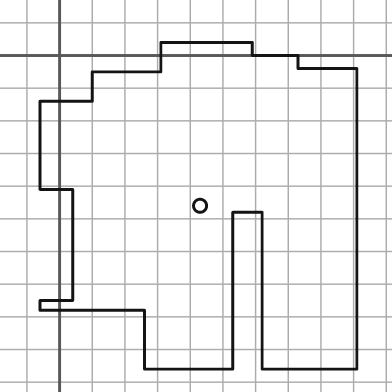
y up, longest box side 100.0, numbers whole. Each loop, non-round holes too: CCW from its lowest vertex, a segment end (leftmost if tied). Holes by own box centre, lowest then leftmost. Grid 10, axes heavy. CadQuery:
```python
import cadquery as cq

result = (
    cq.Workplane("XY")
    .moveTo(26.0, -96.0)
    .lineTo(53.0, -96.0)
    .lineTo(53.0, -48.0)
    .lineTo(62.0, -48.0)
    .lineTo(62.0, -96.0)
    .lineTo(91.0, -96.0)
    .lineTo(91.0, -4.0)
    .lineTo(73.0, -4.0)
    .lineTo(73.0, 0.0)
    .lineTo(59.0, 0.0)
    .lineTo(59.0, 4.0)
    .lineTo(31.0, 4.0)
    .lineTo(31.0, -5.0)
    .lineTo(10.0, -5.0)
    .lineTo(10.0, -14.0)
    .lineTo(-6.0, -14.0)
    .lineTo(-6.0, -41.0)
    .lineTo(4.0, -41.0)
    .lineTo(4.0, -75.0)
    .lineTo(-6.0, -75.0)
    .lineTo(-6.0, -78.0)
    .lineTo(26.0, -78.0)
    .close()
    .moveTo(43.0, -46.0)
    .circle(2.0)
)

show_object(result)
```